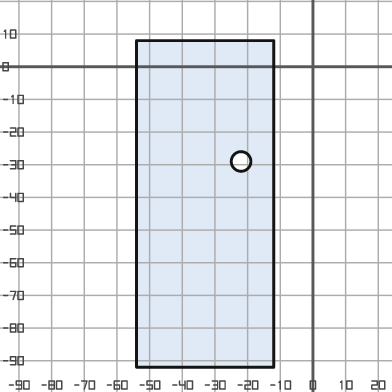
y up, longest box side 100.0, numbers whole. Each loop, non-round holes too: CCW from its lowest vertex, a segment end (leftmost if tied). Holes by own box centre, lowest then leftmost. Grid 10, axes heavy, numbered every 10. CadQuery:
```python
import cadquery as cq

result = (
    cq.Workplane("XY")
    .moveTo(-54.0, -92.0)
    .lineTo(-12.0, -92.0)
    .lineTo(-12.0, 8.0)
    .lineTo(-54.0, 8.0)
    .close()
    .moveTo(-22.0, -29.0)
    .circle(3.0)
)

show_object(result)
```